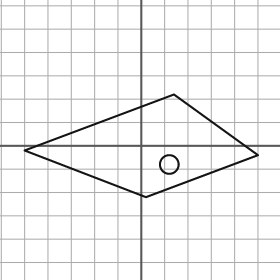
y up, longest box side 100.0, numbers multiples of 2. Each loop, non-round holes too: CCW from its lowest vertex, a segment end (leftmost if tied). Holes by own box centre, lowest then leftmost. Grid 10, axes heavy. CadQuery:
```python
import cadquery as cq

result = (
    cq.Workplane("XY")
    .moveTo(2.0, -22.0)
    .lineTo(50.0, -4.0)
    .lineTo(14.0, 22.0)
    .lineTo(-50.0, -2.0)
    .close()
    .moveTo(12.0, -8.0)
    .circle(4.0)
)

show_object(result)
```